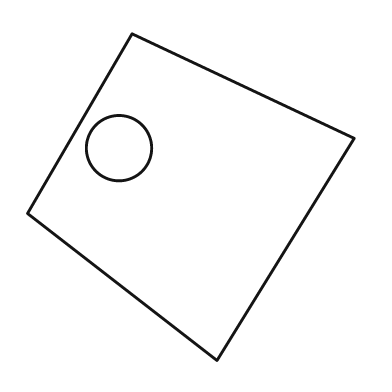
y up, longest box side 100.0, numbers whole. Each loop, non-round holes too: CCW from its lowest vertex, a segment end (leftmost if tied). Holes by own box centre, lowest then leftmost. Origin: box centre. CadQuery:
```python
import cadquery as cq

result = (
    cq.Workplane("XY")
    .moveTo(8.0, -50.0)
    .lineTo(50.0, 18.0)
    .lineTo(-18.0, 50.0)
    .lineTo(-50.0, -5.0)
    .close()
    .moveTo(-22.0, 15.0)
    .circle(10.0)
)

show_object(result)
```